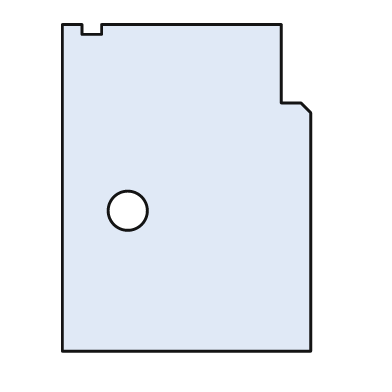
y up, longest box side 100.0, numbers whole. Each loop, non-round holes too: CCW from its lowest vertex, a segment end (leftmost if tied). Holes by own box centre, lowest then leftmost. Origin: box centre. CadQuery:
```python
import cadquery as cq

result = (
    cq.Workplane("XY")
    .moveTo(-38.0, -50.0)
    .lineTo(38.0, -50.0)
    .lineTo(38.0, 23.0)
    .lineTo(35.0, 26.0)
    .lineTo(29.0, 26.0)
    .lineTo(29.0, 50.0)
    .lineTo(-26.0, 50.0)
    .lineTo(-26.0, 47.0)
    .lineTo(-32.0, 47.0)
    .lineTo(-32.0, 50.0)
    .lineTo(-38.0, 50.0)
    .close()
    .moveTo(-18.0, -7.0)
    .circle(6.0)
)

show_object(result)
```